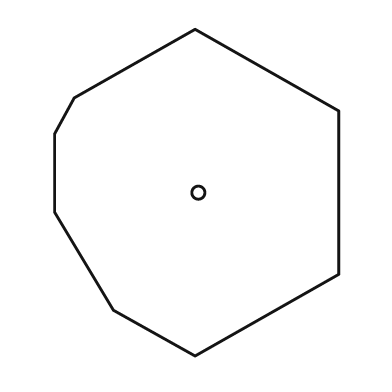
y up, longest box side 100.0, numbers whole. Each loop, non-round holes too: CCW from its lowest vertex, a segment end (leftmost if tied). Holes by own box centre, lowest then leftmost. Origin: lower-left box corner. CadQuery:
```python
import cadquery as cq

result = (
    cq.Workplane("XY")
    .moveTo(43.0, 0.0)
    .lineTo(87.0, 25.0)
    .lineTo(87.0, 75.0)
    .lineTo(43.0, 100.0)
    .lineTo(6.0, 79.0)
    .lineTo(0.0, 68.0)
    .lineTo(0.0, 44.0)
    .lineTo(18.0, 14.0)
    .close()
    .moveTo(44.0, 50.0)
    .circle(2.0)
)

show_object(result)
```